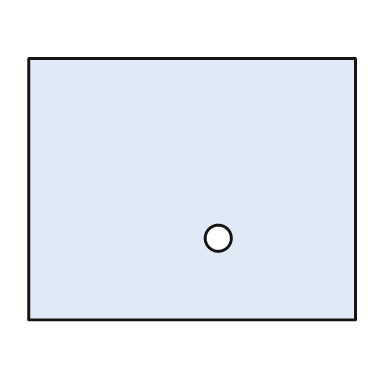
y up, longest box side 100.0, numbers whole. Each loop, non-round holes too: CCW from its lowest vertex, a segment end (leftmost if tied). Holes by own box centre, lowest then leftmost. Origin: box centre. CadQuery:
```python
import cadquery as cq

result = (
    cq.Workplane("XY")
    .moveTo(-50.0, -40.0)
    .lineTo(50.0, -40.0)
    .lineTo(50.0, 40.0)
    .lineTo(-50.0, 40.0)
    .close()
    .moveTo(8.0, -15.0)
    .circle(4.0)
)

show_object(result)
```